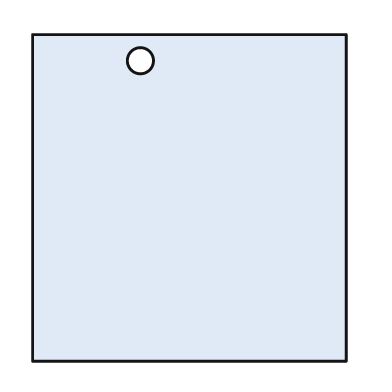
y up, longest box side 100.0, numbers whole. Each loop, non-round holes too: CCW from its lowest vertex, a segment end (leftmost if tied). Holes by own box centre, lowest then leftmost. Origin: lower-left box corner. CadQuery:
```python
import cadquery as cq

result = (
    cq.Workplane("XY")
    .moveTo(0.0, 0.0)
    .lineTo(96.0, 0.0)
    .lineTo(96.0, 100.0)
    .lineTo(0.0, 100.0)
    .close()
    .moveTo(33.0, 92.0)
    .circle(4.0)
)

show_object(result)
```